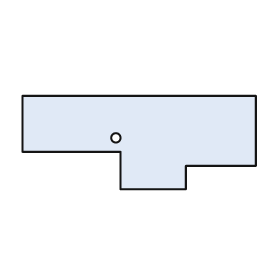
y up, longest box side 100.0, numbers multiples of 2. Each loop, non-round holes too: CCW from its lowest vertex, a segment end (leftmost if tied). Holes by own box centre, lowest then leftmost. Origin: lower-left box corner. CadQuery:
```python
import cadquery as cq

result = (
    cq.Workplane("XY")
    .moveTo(42.0, 0.0)
    .lineTo(70.0, 0.0)
    .lineTo(70.0, 10.0)
    .lineTo(100.0, 10.0)
    .lineTo(100.0, 40.0)
    .lineTo(0.0, 40.0)
    .lineTo(0.0, 16.0)
    .lineTo(42.0, 16.0)
    .close()
    .moveTo(40.0, 22.0)
    .circle(2.0)
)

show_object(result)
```